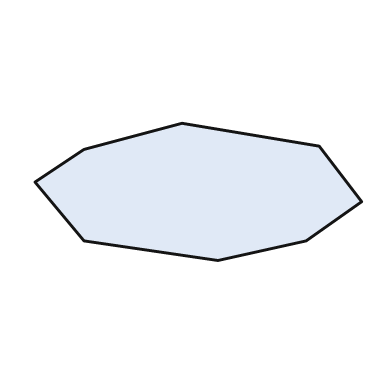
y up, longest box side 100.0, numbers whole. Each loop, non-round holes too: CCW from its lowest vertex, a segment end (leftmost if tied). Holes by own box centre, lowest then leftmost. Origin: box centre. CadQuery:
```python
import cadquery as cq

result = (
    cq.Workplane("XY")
    .moveTo(6.0, -21.0)
    .lineTo(33.0, -15.0)
    .lineTo(50.0, -3.0)
    .lineTo(37.0, 14.0)
    .lineTo(-5.0, 21.0)
    .lineTo(-35.0, 13.0)
    .lineTo(-50.0, 3.0)
    .lineTo(-35.0, -15.0)
    .close()
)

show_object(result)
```